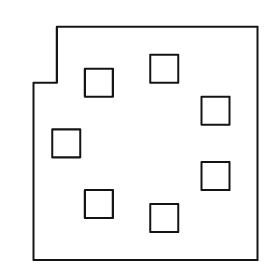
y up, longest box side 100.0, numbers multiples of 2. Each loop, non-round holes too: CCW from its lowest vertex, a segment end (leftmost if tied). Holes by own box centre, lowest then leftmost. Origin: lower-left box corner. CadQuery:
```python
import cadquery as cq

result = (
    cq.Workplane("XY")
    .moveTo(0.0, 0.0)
    .lineTo(96.0, 0.0)
    .lineTo(96.0, 100.0)
    .lineTo(10.0, 100.0)
    .lineTo(10.0, 76.0)
    .lineTo(0.0, 76.0)
    .close()
    .moveTo(50.0, 12.0)
    .lineTo(62.0, 12.0)
    .lineTo(62.0, 24.0)
    .lineTo(50.0, 24.0)
    .close()
    .moveTo(22.0, 18.0)
    .lineTo(34.0, 18.0)
    .lineTo(34.0, 30.0)
    .lineTo(22.0, 30.0)
    .close()
    .moveTo(72.0, 30.0)
    .lineTo(84.0, 30.0)
    .lineTo(84.0, 42.0)
    .lineTo(72.0, 42.0)
    .close()
    .moveTo(8.0, 44.0)
    .lineTo(20.0, 44.0)
    .lineTo(20.0, 56.0)
    .lineTo(8.0, 56.0)
    .close()
    .moveTo(72.0, 58.0)
    .lineTo(84.0, 58.0)
    .lineTo(84.0, 70.0)
    .lineTo(72.0, 70.0)
    .close()
    .moveTo(22.0, 70.0)
    .lineTo(34.0, 70.0)
    .lineTo(34.0, 82.0)
    .lineTo(22.0, 82.0)
    .close()
    .moveTo(50.0, 76.0)
    .lineTo(62.0, 76.0)
    .lineTo(62.0, 88.0)
    .lineTo(50.0, 88.0)
    .close()
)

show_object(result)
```